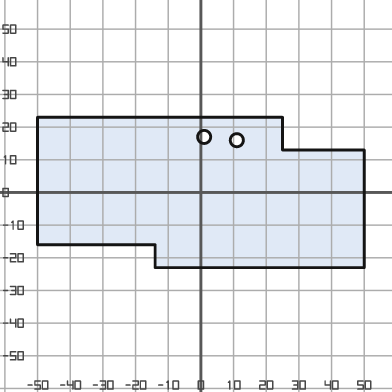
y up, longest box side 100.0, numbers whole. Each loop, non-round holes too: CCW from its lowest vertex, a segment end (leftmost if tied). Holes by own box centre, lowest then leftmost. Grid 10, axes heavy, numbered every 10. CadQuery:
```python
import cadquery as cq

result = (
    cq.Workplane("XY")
    .moveTo(-14.0, -23.0)
    .lineTo(50.0, -23.0)
    .lineTo(50.0, 13.0)
    .lineTo(25.0, 13.0)
    .lineTo(25.0, 23.0)
    .lineTo(-50.0, 23.0)
    .lineTo(-50.0, -16.0)
    .lineTo(-14.0, -16.0)
    .close()
    .moveTo(11.0, 16.0)
    .circle(2.0)
    .moveTo(1.0, 17.0)
    .circle(2.0)
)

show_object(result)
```